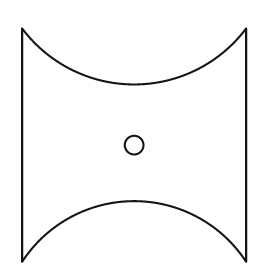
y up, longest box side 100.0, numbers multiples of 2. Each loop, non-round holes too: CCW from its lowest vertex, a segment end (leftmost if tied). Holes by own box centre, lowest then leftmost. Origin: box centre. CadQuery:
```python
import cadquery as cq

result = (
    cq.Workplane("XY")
    .moveTo(-48.0, -50.0)
    .threePointArc((0.0, -24.0), (48.0, -50.0))
    .lineTo(48.0, 50.0)
    .threePointArc((0.0, 26.0), (-48.0, 50.0))
    .close()
    .moveTo(0.0, 0.0)
    .circle(4.0)
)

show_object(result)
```